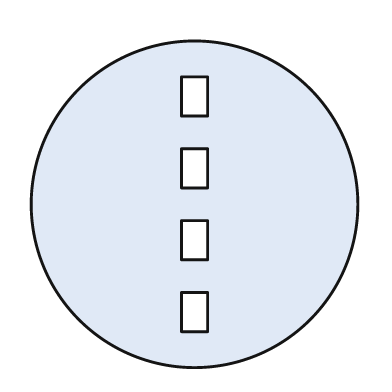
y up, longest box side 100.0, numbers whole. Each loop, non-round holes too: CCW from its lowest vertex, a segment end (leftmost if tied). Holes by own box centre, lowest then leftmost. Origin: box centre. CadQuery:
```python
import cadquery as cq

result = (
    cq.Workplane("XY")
    .moveTo(0.0, 0.0)
    .circle(50.0)
    .moveTo(-4.0, -39.0)
    .lineTo(4.0, -39.0)
    .lineTo(4.0, -27.0)
    .lineTo(-4.0, -27.0)
    .close()
    .moveTo(-4.0, -17.0)
    .lineTo(4.0, -17.0)
    .lineTo(4.0, -5.0)
    .lineTo(-4.0, -5.0)
    .close()
    .moveTo(-4.0, 5.0)
    .lineTo(4.0, 5.0)
    .lineTo(4.0, 17.0)
    .lineTo(-4.0, 17.0)
    .close()
    .moveTo(-4.0, 27.0)
    .lineTo(4.0, 27.0)
    .lineTo(4.0, 39.0)
    .lineTo(-4.0, 39.0)
    .close()
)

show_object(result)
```